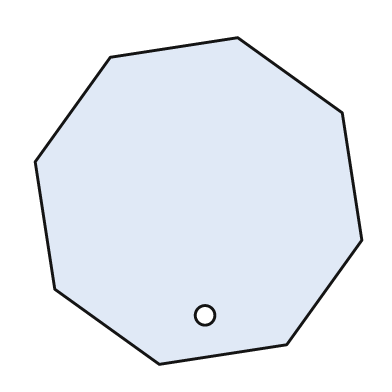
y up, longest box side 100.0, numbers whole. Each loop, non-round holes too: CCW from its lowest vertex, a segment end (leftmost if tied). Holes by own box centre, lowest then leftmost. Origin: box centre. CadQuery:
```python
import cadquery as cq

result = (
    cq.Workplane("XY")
    .moveTo(-12.0, -50.0)
    .lineTo(27.0, -44.0)
    .lineTo(50.0, -12.0)
    .lineTo(44.0, 27.0)
    .lineTo(12.0, 50.0)
    .lineTo(-27.0, 44.0)
    .lineTo(-50.0, 12.0)
    .lineTo(-44.0, -27.0)
    .close()
    .moveTo(2.0, -35.0)
    .circle(3.0)
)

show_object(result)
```